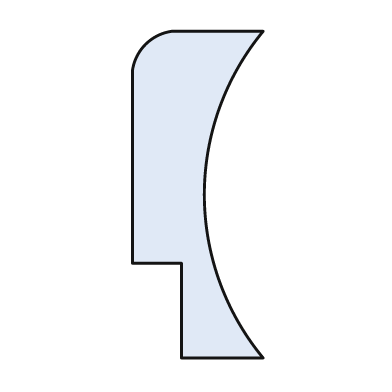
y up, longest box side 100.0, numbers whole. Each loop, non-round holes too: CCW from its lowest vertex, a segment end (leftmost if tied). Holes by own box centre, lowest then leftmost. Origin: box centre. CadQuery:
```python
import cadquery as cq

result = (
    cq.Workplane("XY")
    .moveTo(-5.0, -50.0)
    .lineTo(20.0, -50.0)
    .threePointArc((2.0, 0.0), (20.0, 50.0))
    .lineTo(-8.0, 50.0)
    .threePointArc((-16.0, 46.0), (-20.0, 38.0))
    .lineTo(-20.0, -21.0)
    .lineTo(-5.0, -21.0)
    .close()
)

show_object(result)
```